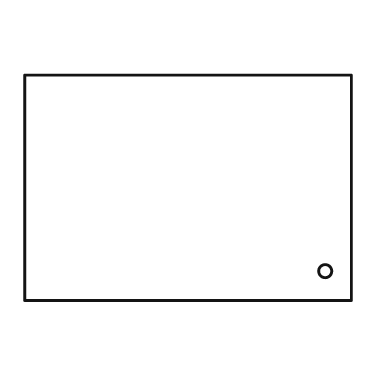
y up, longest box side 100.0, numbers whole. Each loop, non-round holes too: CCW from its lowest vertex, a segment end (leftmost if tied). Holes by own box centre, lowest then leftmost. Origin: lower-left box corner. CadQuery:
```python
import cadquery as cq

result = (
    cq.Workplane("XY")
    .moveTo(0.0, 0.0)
    .lineTo(100.0, 0.0)
    .lineTo(100.0, 69.0)
    .lineTo(0.0, 69.0)
    .close()
    .moveTo(92.0, 9.0)
    .circle(2.0)
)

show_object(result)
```